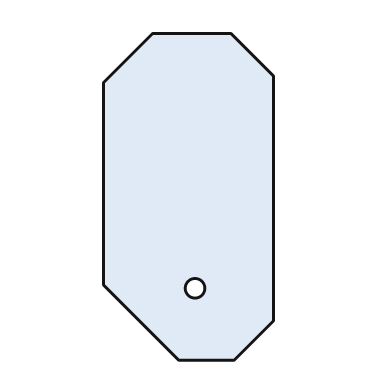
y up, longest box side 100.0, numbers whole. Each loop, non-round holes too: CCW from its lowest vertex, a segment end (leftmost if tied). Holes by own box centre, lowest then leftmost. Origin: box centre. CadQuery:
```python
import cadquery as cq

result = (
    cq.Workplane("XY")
    .moveTo(-3.0, -50.0)
    .lineTo(14.0, -50.0)
    .lineTo(26.0, -38.0)
    .lineTo(26.0, 37.0)
    .lineTo(13.0, 50.0)
    .lineTo(-11.0, 50.0)
    .lineTo(-26.0, 35.0)
    .lineTo(-26.0, -27.0)
    .close()
    .moveTo(2.0, -28.0)
    .circle(3.0)
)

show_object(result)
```